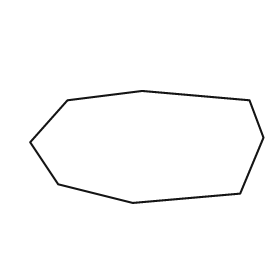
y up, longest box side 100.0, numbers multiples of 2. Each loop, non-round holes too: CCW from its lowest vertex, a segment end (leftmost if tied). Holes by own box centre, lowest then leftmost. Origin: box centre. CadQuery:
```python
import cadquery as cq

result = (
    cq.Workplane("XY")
    .moveTo(-6.0, -24.0)
    .lineTo(40.0, -20.0)
    .lineTo(50.0, 4.0)
    .lineTo(44.0, 20.0)
    .lineTo(-2.0, 24.0)
    .lineTo(-34.0, 20.0)
    .lineTo(-50.0, 2.0)
    .lineTo(-38.0, -16.0)
    .close()
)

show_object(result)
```